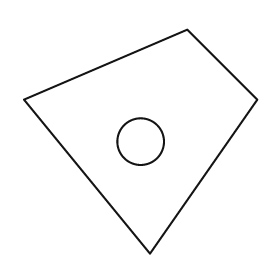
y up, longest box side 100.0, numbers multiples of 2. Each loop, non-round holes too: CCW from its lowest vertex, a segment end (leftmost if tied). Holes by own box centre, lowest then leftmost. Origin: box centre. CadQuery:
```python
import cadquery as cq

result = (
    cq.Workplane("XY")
    .moveTo(4.0, -48.0)
    .lineTo(50.0, 18.0)
    .lineTo(20.0, 48.0)
    .lineTo(-50.0, 18.0)
    .close()
    .moveTo(0.0, 0.0)
    .circle(10.0)
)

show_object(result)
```